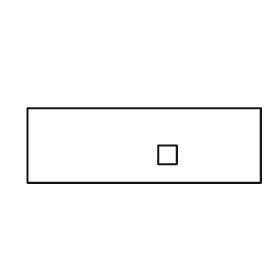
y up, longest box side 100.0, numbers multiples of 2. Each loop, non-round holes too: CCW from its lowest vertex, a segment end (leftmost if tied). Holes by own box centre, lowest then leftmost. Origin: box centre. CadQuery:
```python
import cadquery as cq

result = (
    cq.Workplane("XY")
    .moveTo(-50.0, -16.0)
    .lineTo(50.0, -16.0)
    .lineTo(50.0, 16.0)
    .lineTo(-50.0, 16.0)
    .close()
    .moveTo(6.0, -8.0)
    .lineTo(14.0, -8.0)
    .lineTo(14.0, 0.0)
    .lineTo(6.0, 0.0)
    .close()
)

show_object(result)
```